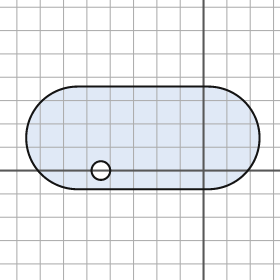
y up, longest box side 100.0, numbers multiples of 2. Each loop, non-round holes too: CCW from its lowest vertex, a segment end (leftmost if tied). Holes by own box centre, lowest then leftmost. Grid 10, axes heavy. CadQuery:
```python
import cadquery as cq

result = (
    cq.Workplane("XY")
    .moveTo(-54.0, -8.0)
    .lineTo(2.0, -8.0)
    .threePointArc((24.0, 14.0), (2.0, 36.0))
    .lineTo(-54.0, 36.0)
    .threePointArc((-76.0, 14.0), (-54.0, -8.0))
    .close()
    .moveTo(-44.0, 0.0)
    .circle(4.0)
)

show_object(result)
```